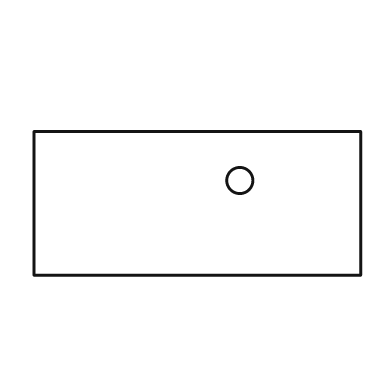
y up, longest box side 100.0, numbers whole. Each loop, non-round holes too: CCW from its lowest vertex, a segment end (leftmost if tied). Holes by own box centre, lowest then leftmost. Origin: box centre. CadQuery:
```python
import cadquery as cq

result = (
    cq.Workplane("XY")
    .moveTo(-50.0, -22.0)
    .lineTo(50.0, -22.0)
    .lineTo(50.0, 22.0)
    .lineTo(-50.0, 22.0)
    .close()
    .moveTo(13.0, 7.0)
    .circle(4.0)
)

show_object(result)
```